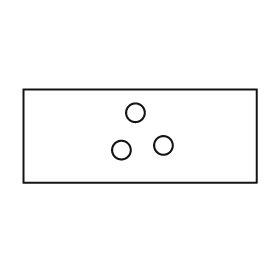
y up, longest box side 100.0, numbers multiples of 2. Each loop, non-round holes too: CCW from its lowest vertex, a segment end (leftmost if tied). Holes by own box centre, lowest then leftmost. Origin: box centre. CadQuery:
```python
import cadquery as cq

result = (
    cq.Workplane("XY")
    .moveTo(-50.0, -20.0)
    .lineTo(50.0, -20.0)
    .lineTo(50.0, 20.0)
    .lineTo(-50.0, 20.0)
    .close()
    .moveTo(-8.0, -6.0)
    .circle(4.0)
    .moveTo(10.0, -4.0)
    .circle(4.0)
    .moveTo(-2.0, 10.0)
    .circle(4.0)
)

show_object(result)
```